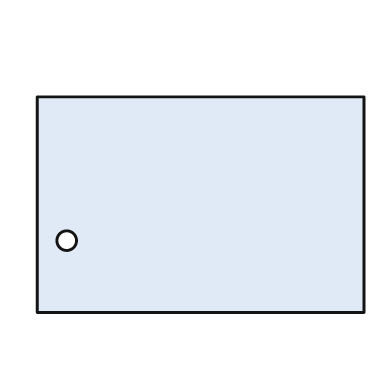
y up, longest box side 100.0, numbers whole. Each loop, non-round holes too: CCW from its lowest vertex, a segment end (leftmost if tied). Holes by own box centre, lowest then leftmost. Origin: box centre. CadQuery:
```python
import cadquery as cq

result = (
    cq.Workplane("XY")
    .moveTo(-50.0, -33.0)
    .lineTo(50.0, -33.0)
    .lineTo(50.0, 33.0)
    .lineTo(-50.0, 33.0)
    .close()
    .moveTo(-41.0, -11.0)
    .circle(3.0)
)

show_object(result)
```